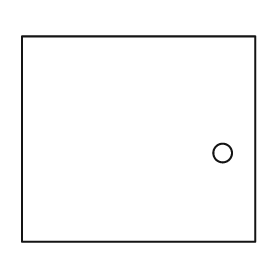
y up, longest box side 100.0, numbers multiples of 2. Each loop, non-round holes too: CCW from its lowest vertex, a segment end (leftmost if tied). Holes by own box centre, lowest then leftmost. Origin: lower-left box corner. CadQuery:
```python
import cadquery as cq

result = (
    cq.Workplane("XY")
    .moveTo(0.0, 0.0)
    .lineTo(100.0, 0.0)
    .lineTo(100.0, 88.0)
    .lineTo(0.0, 88.0)
    .close()
    .moveTo(86.0, 38.0)
    .circle(4.0)
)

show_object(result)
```